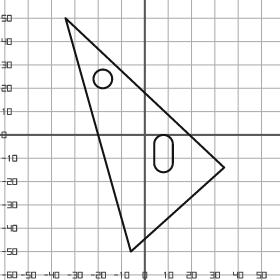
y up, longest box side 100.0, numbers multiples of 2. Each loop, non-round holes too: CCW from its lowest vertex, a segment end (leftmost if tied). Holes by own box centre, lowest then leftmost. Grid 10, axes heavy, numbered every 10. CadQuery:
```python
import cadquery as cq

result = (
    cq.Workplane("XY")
    .moveTo(-6.0, -50.0)
    .lineTo(34.0, -14.0)
    .lineTo(-34.0, 50.0)
    .close()
    .moveTo(4.0, -12.0)
    .threePointArc((8.0, -16.0), (12.0, -12.0))
    .lineTo(12.0, -4.0)
    .threePointArc((8.0, 0.0), (4.0, -4.0))
    .close()
    .moveTo(-18.0, 24.0)
    .circle(4.0)
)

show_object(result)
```